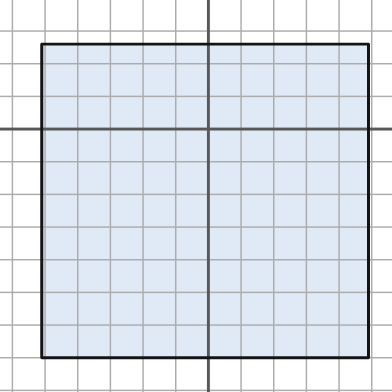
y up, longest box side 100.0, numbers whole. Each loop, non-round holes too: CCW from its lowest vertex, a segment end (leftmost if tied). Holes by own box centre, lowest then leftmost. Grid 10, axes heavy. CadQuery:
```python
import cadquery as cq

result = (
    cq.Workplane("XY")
    .moveTo(-51.0, -70.0)
    .lineTo(49.0, -70.0)
    .lineTo(49.0, 26.0)
    .lineTo(-51.0, 26.0)
    .close()
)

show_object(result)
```